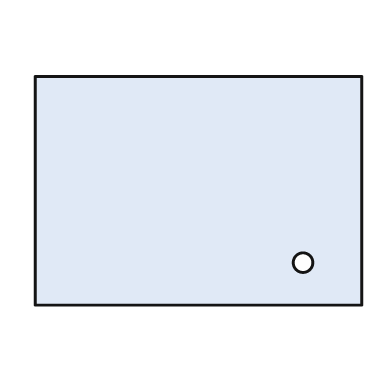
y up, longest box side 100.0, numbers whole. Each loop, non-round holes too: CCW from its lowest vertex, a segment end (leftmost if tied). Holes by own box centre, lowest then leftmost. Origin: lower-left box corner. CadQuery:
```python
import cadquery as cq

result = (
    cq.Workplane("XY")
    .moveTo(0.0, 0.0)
    .lineTo(100.0, 0.0)
    .lineTo(100.0, 70.0)
    .lineTo(0.0, 70.0)
    .close()
    .moveTo(82.0, 13.0)
    .circle(3.0)
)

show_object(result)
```